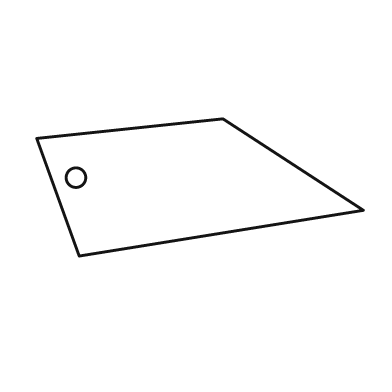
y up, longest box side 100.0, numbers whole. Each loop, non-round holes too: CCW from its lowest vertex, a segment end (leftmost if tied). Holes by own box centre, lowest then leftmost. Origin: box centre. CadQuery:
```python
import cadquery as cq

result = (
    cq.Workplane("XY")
    .moveTo(-37.0, -21.0)
    .lineTo(50.0, -7.0)
    .lineTo(7.0, 21.0)
    .lineTo(-50.0, 15.0)
    .close()
    .moveTo(-38.0, 3.0)
    .circle(3.0)
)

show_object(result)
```